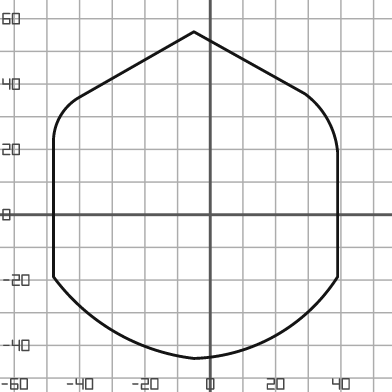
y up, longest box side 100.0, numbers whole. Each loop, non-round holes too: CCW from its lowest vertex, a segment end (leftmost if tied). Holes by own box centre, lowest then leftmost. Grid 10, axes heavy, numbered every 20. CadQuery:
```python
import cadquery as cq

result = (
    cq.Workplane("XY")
    .moveTo(-5.0, -44.0)
    .threePointArc((20.0, -37.0), (39.0, -19.0))
    .lineTo(39.0, 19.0)
    .threePointArc((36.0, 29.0), (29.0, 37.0))
    .lineTo(-5.0, 56.0)
    .lineTo(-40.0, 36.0)
    .threePointArc((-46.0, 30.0), (-48.0, 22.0))
    .lineTo(-48.0, -19.0)
    .threePointArc((-29.0, -36.0), (-5.0, -44.0))
    .close()
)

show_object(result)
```